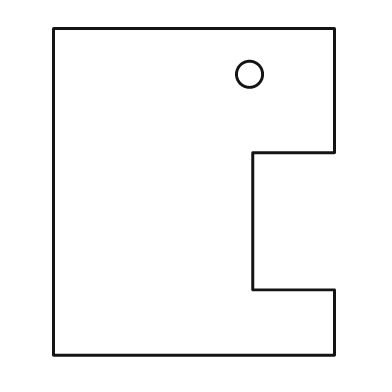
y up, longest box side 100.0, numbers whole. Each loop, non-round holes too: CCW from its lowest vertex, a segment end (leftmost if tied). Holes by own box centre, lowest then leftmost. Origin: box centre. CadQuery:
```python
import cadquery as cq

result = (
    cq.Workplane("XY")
    .moveTo(-43.0, -50.0)
    .lineTo(43.0, -50.0)
    .lineTo(43.0, -30.0)
    .lineTo(18.0, -30.0)
    .lineTo(18.0, 12.0)
    .lineTo(43.0, 12.0)
    .lineTo(43.0, 50.0)
    .lineTo(-43.0, 50.0)
    .close()
    .moveTo(17.0, 36.0)
    .circle(4.0)
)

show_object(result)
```